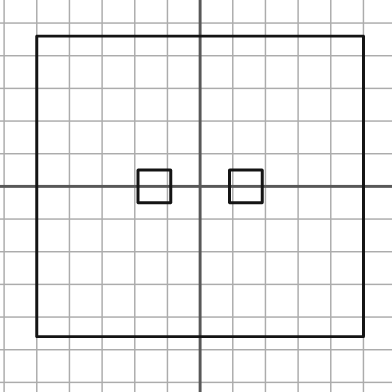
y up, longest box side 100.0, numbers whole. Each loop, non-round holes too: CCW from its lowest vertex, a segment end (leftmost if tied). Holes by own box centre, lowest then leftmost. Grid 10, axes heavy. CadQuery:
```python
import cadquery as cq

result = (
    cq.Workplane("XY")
    .moveTo(-50.0, -46.0)
    .lineTo(50.0, -46.0)
    .lineTo(50.0, 46.0)
    .lineTo(-50.0, 46.0)
    .close()
    .moveTo(-19.0, -5.0)
    .lineTo(-9.0, -5.0)
    .lineTo(-9.0, 5.0)
    .lineTo(-19.0, 5.0)
    .close()
    .moveTo(9.0, -5.0)
    .lineTo(19.0, -5.0)
    .lineTo(19.0, 5.0)
    .lineTo(9.0, 5.0)
    .close()
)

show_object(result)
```